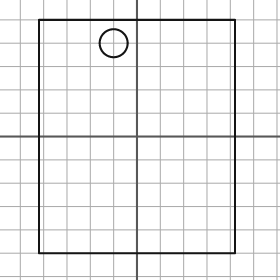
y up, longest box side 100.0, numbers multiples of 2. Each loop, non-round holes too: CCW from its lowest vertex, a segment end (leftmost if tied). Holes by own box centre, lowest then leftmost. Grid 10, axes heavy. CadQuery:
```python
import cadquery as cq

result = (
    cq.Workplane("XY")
    .moveTo(-42.0, -50.0)
    .lineTo(42.0, -50.0)
    .lineTo(42.0, 50.0)
    .lineTo(-42.0, 50.0)
    .close()
    .moveTo(-10.0, 40.0)
    .circle(6.0)
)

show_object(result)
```